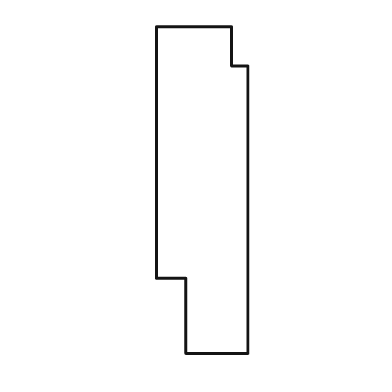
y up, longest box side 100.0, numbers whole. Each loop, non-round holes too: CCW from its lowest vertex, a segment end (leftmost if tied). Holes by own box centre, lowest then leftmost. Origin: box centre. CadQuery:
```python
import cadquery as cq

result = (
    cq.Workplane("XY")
    .moveTo(-5.0, -50.0)
    .lineTo(14.0, -50.0)
    .lineTo(14.0, 38.0)
    .lineTo(9.0, 38.0)
    .lineTo(9.0, 50.0)
    .lineTo(-14.0, 50.0)
    .lineTo(-14.0, -27.0)
    .lineTo(-5.0, -27.0)
    .close()
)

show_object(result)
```